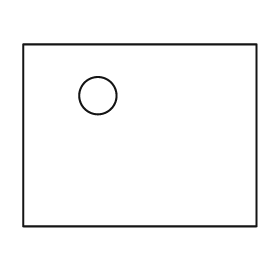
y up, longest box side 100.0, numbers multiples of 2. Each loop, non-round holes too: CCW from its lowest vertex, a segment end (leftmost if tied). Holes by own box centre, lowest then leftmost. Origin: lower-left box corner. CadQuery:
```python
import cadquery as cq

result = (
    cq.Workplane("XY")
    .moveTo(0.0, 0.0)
    .lineTo(100.0, 0.0)
    .lineTo(100.0, 78.0)
    .lineTo(0.0, 78.0)
    .close()
    .moveTo(32.0, 56.0)
    .circle(8.0)
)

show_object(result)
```